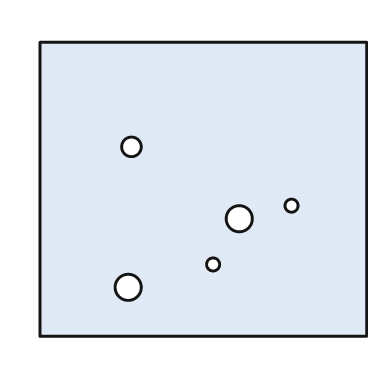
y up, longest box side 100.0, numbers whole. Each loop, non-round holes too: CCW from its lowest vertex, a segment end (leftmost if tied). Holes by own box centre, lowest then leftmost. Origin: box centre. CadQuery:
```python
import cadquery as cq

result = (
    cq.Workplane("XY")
    .moveTo(-50.0, -45.0)
    .lineTo(50.0, -45.0)
    .lineTo(50.0, 45.0)
    .lineTo(-50.0, 45.0)
    .close()
    .moveTo(-23.0, -30.0)
    .circle(4.0)
    .moveTo(3.0, -23.0)
    .circle(2.0)
    .moveTo(11.0, -9.0)
    .circle(4.0)
    .moveTo(27.0, -5.0)
    .circle(2.0)
    .moveTo(-22.0, 13.0)
    .circle(3.0)
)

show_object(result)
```